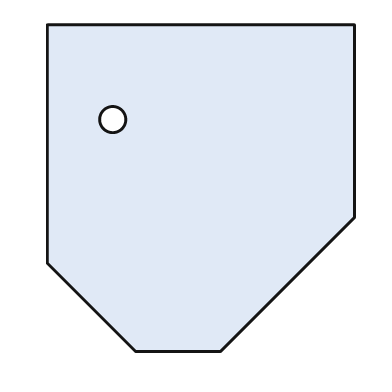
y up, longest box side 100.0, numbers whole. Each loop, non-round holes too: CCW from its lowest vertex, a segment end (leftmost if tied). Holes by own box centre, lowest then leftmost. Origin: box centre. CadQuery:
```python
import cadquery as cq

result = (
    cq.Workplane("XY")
    .moveTo(-20.0, -50.0)
    .lineTo(6.0, -50.0)
    .lineTo(47.0, -9.0)
    .lineTo(47.0, 50.0)
    .lineTo(-47.0, 50.0)
    .lineTo(-47.0, -23.0)
    .close()
    .moveTo(-27.0, 21.0)
    .circle(4.0)
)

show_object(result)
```